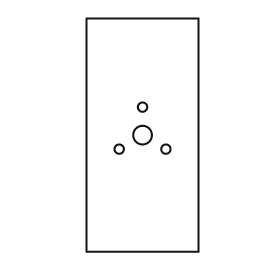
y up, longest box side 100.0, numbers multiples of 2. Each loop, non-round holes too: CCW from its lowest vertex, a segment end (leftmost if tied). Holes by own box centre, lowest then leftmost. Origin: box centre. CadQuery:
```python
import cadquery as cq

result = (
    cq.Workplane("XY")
    .moveTo(-24.0, -50.0)
    .lineTo(24.0, -50.0)
    .lineTo(24.0, 50.0)
    .lineTo(-24.0, 50.0)
    .close()
    .moveTo(-10.0, -6.0)
    .circle(2.0)
    .moveTo(10.0, -6.0)
    .circle(2.0)
    .moveTo(0.0, 0.0)
    .circle(4.0)
    .moveTo(0.0, 12.0)
    .circle(2.0)
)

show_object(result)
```